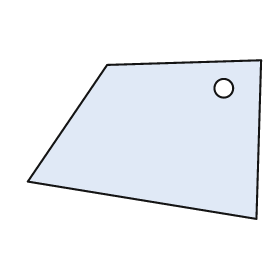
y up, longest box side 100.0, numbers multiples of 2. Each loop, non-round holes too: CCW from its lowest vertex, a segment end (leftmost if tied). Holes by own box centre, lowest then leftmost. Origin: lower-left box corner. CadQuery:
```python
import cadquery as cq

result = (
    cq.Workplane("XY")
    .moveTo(98.0, 0.0)
    .lineTo(100.0, 68.0)
    .lineTo(34.0, 66.0)
    .lineTo(0.0, 16.0)
    .close()
    .moveTo(84.0, 56.0)
    .circle(4.0)
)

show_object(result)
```